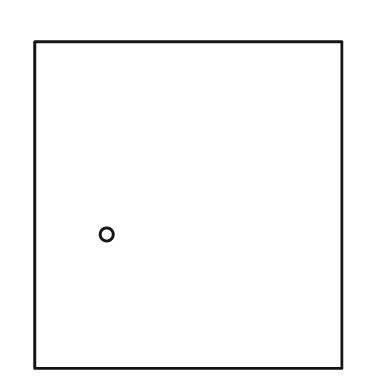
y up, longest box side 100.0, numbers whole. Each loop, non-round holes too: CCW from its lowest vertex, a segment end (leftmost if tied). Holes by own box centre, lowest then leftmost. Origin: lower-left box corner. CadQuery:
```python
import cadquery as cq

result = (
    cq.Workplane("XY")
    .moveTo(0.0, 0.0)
    .lineTo(94.0, 0.0)
    .lineTo(94.0, 100.0)
    .lineTo(0.0, 100.0)
    .close()
    .moveTo(22.0, 41.0)
    .circle(2.0)
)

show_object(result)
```